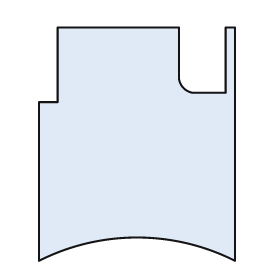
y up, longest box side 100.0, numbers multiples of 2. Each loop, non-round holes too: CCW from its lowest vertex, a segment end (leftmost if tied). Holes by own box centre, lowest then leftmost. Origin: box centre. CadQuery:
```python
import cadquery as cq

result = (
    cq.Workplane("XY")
    .moveTo(-42.0, -50.0)
    .threePointArc((0.0, -40.0), (42.0, -50.0))
    .lineTo(42.0, 50.0)
    .lineTo(38.0, 50.0)
    .lineTo(38.0, 22.0)
    .lineTo(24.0, 22.0)
    .threePointArc((20.0, 24.0), (18.0, 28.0))
    .lineTo(18.0, 50.0)
    .lineTo(-34.0, 50.0)
    .lineTo(-34.0, 18.0)
    .lineTo(-42.0, 18.0)
    .close()
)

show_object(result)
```